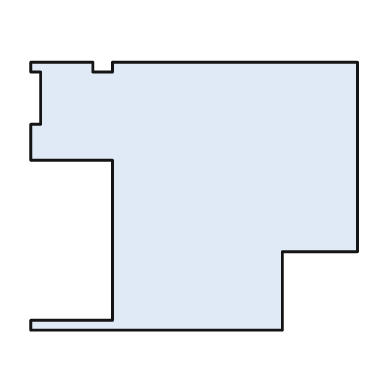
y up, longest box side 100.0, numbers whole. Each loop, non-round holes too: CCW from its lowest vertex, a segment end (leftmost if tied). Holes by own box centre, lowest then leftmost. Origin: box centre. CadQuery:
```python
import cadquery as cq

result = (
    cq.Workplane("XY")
    .moveTo(-50.0, -41.0)
    .lineTo(27.0, -41.0)
    .lineTo(27.0, -17.0)
    .lineTo(50.0, -17.0)
    .lineTo(50.0, 41.0)
    .lineTo(-25.0, 41.0)
    .lineTo(-25.0, 38.0)
    .lineTo(-31.0, 38.0)
    .lineTo(-31.0, 41.0)
    .lineTo(-50.0, 41.0)
    .lineTo(-50.0, 38.0)
    .lineTo(-47.0, 38.0)
    .lineTo(-47.0, 22.0)
    .lineTo(-50.0, 22.0)
    .lineTo(-50.0, 11.0)
    .lineTo(-25.0, 11.0)
    .lineTo(-25.0, -38.0)
    .lineTo(-50.0, -38.0)
    .close()
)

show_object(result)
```